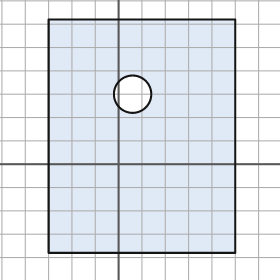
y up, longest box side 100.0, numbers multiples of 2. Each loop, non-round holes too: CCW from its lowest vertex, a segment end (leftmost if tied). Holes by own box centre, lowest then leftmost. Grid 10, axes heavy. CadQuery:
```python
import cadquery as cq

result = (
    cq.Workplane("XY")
    .moveTo(-30.0, -38.0)
    .lineTo(50.0, -38.0)
    .lineTo(50.0, 62.0)
    .lineTo(-30.0, 62.0)
    .close()
    .moveTo(6.0, 30.0)
    .circle(8.0)
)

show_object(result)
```